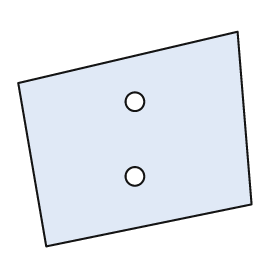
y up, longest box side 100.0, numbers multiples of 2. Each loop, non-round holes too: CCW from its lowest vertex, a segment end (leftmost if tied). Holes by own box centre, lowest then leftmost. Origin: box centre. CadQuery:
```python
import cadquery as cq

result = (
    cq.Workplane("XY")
    .moveTo(-38.0, -46.0)
    .lineTo(50.0, -28.0)
    .lineTo(44.0, 46.0)
    .lineTo(-50.0, 24.0)
    .close()
    .moveTo(0.0, -16.0)
    .circle(4.0)
    .moveTo(0.0, 16.0)
    .circle(4.0)
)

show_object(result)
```